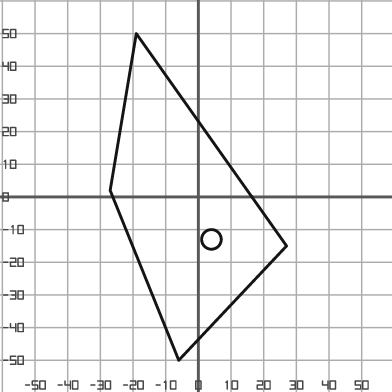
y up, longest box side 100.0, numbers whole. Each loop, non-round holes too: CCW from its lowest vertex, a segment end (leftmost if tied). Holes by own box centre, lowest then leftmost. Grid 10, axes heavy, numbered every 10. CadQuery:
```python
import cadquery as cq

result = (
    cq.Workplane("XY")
    .moveTo(-6.0, -50.0)
    .lineTo(27.0, -15.0)
    .lineTo(-19.0, 50.0)
    .lineTo(-27.0, 2.0)
    .close()
    .moveTo(4.0, -13.0)
    .circle(3.0)
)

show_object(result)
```